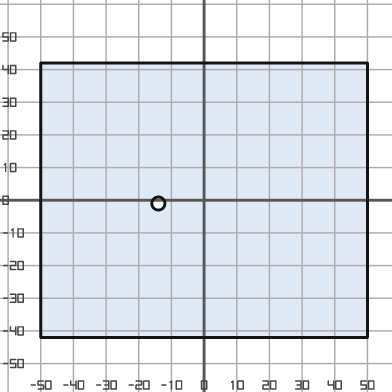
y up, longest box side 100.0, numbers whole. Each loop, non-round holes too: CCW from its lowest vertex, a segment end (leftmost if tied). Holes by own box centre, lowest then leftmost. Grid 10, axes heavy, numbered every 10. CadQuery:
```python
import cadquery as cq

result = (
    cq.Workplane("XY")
    .moveTo(-50.0, -42.0)
    .lineTo(50.0, -42.0)
    .lineTo(50.0, 42.0)
    .lineTo(-50.0, 42.0)
    .close()
    .moveTo(-14.0, -1.0)
    .circle(2.0)
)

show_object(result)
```